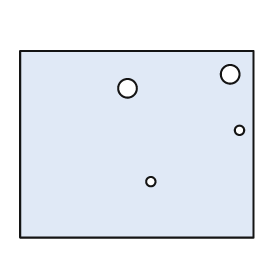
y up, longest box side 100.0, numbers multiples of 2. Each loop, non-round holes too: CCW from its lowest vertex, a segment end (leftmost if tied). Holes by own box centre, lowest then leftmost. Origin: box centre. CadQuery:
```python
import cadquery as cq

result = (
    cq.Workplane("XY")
    .moveTo(-50.0, -40.0)
    .lineTo(50.0, -40.0)
    .lineTo(50.0, 40.0)
    .lineTo(-50.0, 40.0)
    .close()
    .moveTo(6.0, -16.0)
    .circle(2.0)
    .moveTo(44.0, 6.0)
    .circle(2.0)
    .moveTo(-4.0, 24.0)
    .circle(4.0)
    .moveTo(40.0, 30.0)
    .circle(4.0)
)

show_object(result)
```